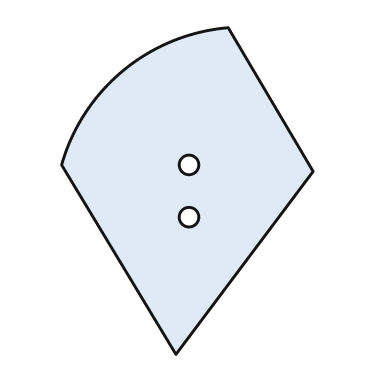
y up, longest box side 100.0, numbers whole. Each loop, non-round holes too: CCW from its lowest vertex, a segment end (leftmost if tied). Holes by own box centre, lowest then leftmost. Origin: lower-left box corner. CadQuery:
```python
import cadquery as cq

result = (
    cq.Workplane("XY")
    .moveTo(35.0, 0.0)
    .lineTo(77.0, 56.0)
    .lineTo(51.0, 100.0)
    .threePointArc((19.0, 87.0), (0.0, 58.0))
    .close()
    .moveTo(39.0, 42.0)
    .circle(3.0)
    .moveTo(39.0, 58.0)
    .circle(3.0)
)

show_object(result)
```